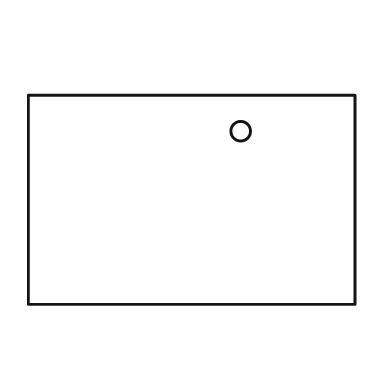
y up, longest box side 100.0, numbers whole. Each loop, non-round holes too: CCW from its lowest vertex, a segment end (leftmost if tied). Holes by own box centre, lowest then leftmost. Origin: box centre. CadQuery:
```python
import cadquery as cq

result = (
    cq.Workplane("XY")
    .moveTo(-50.0, -32.0)
    .lineTo(50.0, -32.0)
    .lineTo(50.0, 32.0)
    .lineTo(-50.0, 32.0)
    .close()
    .moveTo(15.0, 21.0)
    .circle(3.0)
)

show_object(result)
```